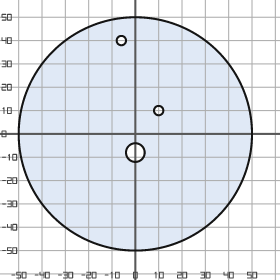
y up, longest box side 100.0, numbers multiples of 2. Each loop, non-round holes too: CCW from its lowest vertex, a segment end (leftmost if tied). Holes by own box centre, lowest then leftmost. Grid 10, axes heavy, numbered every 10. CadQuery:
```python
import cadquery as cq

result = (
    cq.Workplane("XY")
    .moveTo(0.0, 0.0)
    .circle(50.0)
    .moveTo(0.0, -8.0)
    .circle(4.0)
    .moveTo(10.0, 10.0)
    .circle(2.0)
    .moveTo(-6.0, 40.0)
    .circle(2.0)
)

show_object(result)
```